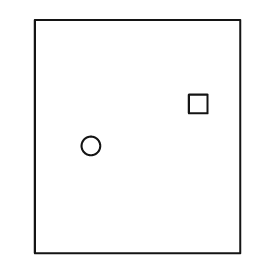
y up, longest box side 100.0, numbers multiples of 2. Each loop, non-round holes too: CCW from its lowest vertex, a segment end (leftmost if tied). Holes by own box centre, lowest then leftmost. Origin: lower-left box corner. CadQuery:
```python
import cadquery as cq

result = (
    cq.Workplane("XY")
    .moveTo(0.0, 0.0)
    .lineTo(88.0, 0.0)
    .lineTo(88.0, 100.0)
    .lineTo(0.0, 100.0)
    .close()
    .moveTo(24.0, 46.0)
    .circle(4.0)
    .moveTo(66.0, 60.0)
    .lineTo(74.0, 60.0)
    .lineTo(74.0, 68.0)
    .lineTo(66.0, 68.0)
    .close()
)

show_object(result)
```